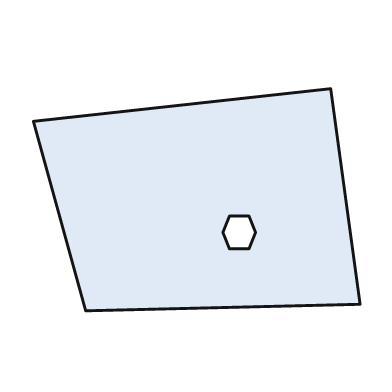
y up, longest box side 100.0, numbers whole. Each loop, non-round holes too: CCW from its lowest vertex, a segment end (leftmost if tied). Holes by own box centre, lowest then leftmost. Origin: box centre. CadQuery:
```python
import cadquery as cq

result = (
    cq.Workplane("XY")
    .moveTo(-34.0, -34.0)
    .lineTo(50.0, -32.0)
    .lineTo(41.0, 34.0)
    .lineTo(-50.0, 24.0)
    .close()
    .moveTo(10.0, -15.0)
    .lineTo(16.0, -15.0)
    .lineTo(18.0, -10.0)
    .lineTo(16.0, -5.0)
    .lineTo(10.0, -5.0)
    .lineTo(8.0, -10.0)
    .close()
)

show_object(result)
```